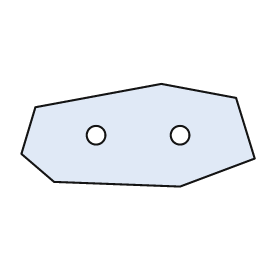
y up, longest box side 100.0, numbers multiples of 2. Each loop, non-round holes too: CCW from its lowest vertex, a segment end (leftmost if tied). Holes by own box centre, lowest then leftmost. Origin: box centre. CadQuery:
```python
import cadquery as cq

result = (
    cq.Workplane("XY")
    .moveTo(18.0, -22.0)
    .lineTo(50.0, -10.0)
    .lineTo(42.0, 16.0)
    .lineTo(10.0, 22.0)
    .lineTo(-44.0, 12.0)
    .lineTo(-50.0, -8.0)
    .lineTo(-36.0, -20.0)
    .close()
    .moveTo(-18.0, 0.0)
    .circle(4.0)
    .moveTo(18.0, 0.0)
    .circle(4.0)
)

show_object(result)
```